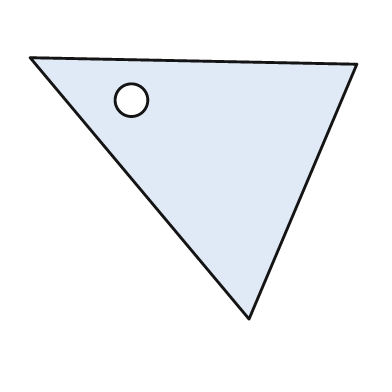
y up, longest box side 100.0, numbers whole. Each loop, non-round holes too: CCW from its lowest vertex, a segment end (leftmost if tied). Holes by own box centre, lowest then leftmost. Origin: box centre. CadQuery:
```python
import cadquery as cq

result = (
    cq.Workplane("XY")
    .moveTo(17.0, -40.0)
    .lineTo(50.0, 38.0)
    .lineTo(-50.0, 40.0)
    .close()
    .moveTo(-19.0, 27.0)
    .circle(5.0)
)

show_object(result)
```